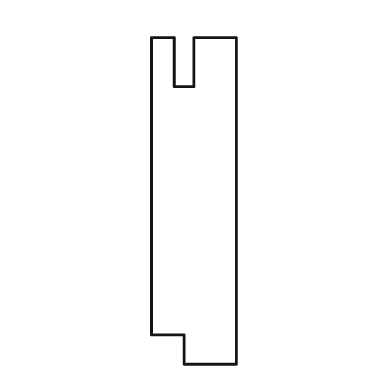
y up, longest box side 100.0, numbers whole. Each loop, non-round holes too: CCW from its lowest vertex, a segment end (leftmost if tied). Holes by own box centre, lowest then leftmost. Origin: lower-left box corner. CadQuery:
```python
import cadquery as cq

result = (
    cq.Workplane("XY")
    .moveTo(10.0, 0.0)
    .lineTo(26.0, 0.0)
    .lineTo(26.0, 100.0)
    .lineTo(13.0, 100.0)
    .lineTo(13.0, 85.0)
    .lineTo(7.0, 85.0)
    .lineTo(7.0, 100.0)
    .lineTo(0.0, 100.0)
    .lineTo(0.0, 9.0)
    .lineTo(10.0, 9.0)
    .close()
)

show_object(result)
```